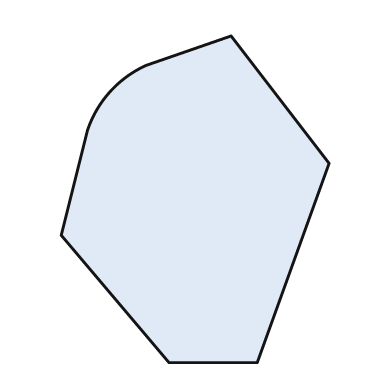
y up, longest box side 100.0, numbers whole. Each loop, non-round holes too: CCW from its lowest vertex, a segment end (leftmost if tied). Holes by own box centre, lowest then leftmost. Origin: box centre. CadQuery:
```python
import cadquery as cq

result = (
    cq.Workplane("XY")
    .moveTo(-8.0, -50.0)
    .lineTo(19.0, -50.0)
    .lineTo(41.0, 11.0)
    .lineTo(11.0, 50.0)
    .lineTo(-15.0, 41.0)
    .threePointArc((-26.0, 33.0), (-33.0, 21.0))
    .lineTo(-41.0, -11.0)
    .close()
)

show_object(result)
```